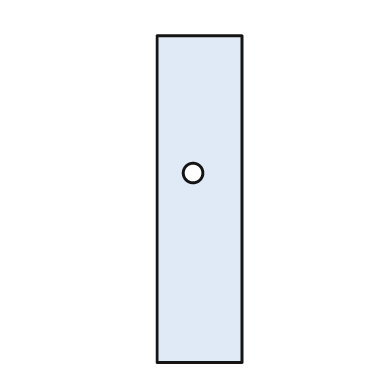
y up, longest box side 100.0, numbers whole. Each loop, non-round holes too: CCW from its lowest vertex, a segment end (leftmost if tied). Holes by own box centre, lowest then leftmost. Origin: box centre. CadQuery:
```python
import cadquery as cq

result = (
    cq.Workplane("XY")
    .moveTo(-13.0, -50.0)
    .lineTo(13.0, -50.0)
    .lineTo(13.0, 50.0)
    .lineTo(-13.0, 50.0)
    .close()
    .moveTo(-2.0, 8.0)
    .circle(3.0)
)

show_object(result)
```